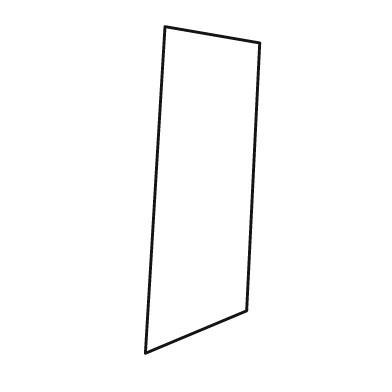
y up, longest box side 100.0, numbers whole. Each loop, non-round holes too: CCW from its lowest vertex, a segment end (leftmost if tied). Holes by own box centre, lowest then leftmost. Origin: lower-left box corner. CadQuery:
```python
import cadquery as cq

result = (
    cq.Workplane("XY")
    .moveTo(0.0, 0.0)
    .lineTo(31.0, 13.0)
    .lineTo(35.0, 95.0)
    .lineTo(6.0, 100.0)
    .close()
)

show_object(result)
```